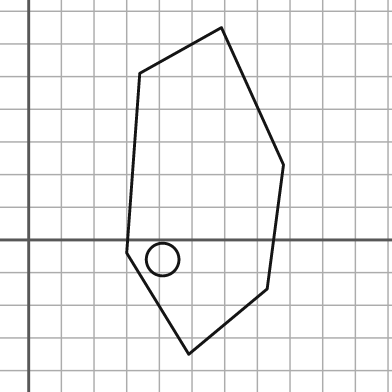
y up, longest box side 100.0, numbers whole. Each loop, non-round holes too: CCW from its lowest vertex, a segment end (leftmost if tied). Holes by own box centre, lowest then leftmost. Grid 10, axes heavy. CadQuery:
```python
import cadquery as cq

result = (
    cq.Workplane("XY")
    .moveTo(49.0, -35.0)
    .lineTo(73.0, -15.0)
    .lineTo(78.0, 23.0)
    .lineTo(59.0, 65.0)
    .lineTo(34.0, 51.0)
    .lineTo(30.0, -4.0)
    .close()
    .moveTo(41.0, -6.0)
    .circle(5.0)
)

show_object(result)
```